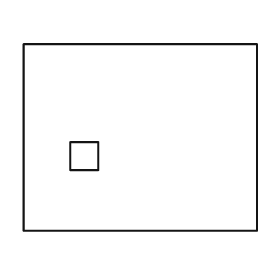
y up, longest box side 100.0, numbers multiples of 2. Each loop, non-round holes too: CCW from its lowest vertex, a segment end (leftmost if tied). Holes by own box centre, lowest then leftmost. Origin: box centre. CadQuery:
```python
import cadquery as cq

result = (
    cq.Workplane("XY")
    .moveTo(-50.0, -40.0)
    .lineTo(50.0, -40.0)
    .lineTo(50.0, 40.0)
    .lineTo(-50.0, 40.0)
    .close()
    .moveTo(-30.0, -14.0)
    .lineTo(-18.0, -14.0)
    .lineTo(-18.0, -2.0)
    .lineTo(-30.0, -2.0)
    .close()
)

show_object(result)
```